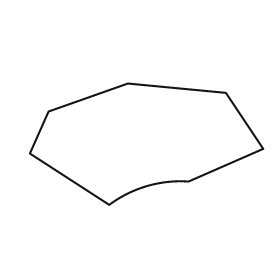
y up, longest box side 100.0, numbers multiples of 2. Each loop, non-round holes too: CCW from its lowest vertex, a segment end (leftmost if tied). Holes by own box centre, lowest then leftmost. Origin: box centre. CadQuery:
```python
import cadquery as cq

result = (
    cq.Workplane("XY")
    .moveTo(-16.0, -26.0)
    .threePointArc((0.0, -18.0), (18.0, -16.0))
    .lineTo(50.0, -2.0)
    .lineTo(34.0, 22.0)
    .lineTo(-8.0, 26.0)
    .lineTo(-42.0, 14.0)
    .lineTo(-50.0, -4.0)
    .close()
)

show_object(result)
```